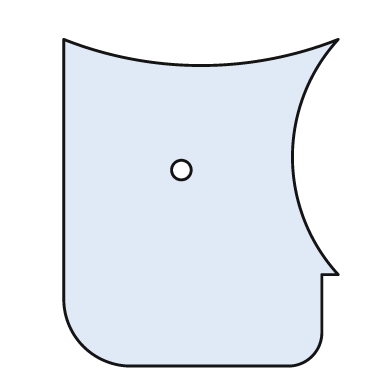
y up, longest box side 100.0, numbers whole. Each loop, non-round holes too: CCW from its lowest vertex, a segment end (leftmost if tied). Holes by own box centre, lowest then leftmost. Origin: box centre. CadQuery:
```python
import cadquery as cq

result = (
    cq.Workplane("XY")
    .moveTo(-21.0, -50.0)
    .lineTo(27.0, -50.0)
    .threePointArc((34.0, -47.0), (37.0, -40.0))
    .lineTo(37.0, -22.0)
    .lineTo(42.0, -22.0)
    .threePointArc((28.0, 14.0), (42.0, 50.0))
    .threePointArc((0.0, 42.0), (-42.0, 50.0))
    .lineTo(-42.0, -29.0)
    .threePointArc((-36.0, -44.0), (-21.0, -50.0))
    .close()
    .moveTo(-6.0, 10.0)
    .circle(3.0)
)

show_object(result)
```